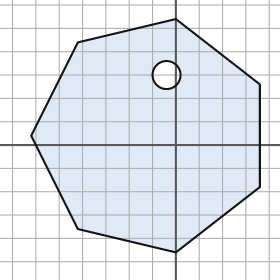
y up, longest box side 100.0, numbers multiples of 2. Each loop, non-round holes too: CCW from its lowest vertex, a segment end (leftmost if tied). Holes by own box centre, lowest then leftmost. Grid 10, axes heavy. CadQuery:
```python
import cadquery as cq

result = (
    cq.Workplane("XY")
    .moveTo(0.0, -46.0)
    .lineTo(36.0, -18.0)
    .lineTo(36.0, 26.0)
    .lineTo(0.0, 54.0)
    .lineTo(-42.0, 44.0)
    .lineTo(-62.0, 4.0)
    .lineTo(-42.0, -36.0)
    .close()
    .moveTo(-4.0, 30.0)
    .circle(6.0)
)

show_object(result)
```